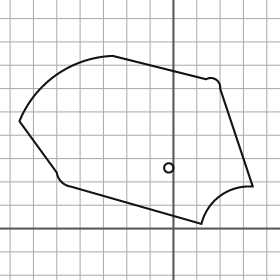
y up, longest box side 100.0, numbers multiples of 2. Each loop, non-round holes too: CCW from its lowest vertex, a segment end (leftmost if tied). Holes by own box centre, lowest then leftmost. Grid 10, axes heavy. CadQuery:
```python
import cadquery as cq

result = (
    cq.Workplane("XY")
    .moveTo(12.0, 2.0)
    .threePointArc((20.0, 14.0), (34.0, 18.0))
    .lineTo(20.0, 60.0)
    .threePointArc((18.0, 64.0), (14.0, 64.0))
    .lineTo(-26.0, 74.0)
    .threePointArc((-50.0, 66.0), (-66.0, 46.0))
    .lineTo(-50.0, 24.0)
    .threePointArc((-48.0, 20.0), (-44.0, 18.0))
    .close()
    .moveTo(-2.0, 26.0)
    .circle(2.0)
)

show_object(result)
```